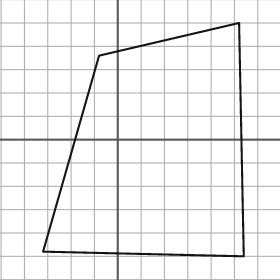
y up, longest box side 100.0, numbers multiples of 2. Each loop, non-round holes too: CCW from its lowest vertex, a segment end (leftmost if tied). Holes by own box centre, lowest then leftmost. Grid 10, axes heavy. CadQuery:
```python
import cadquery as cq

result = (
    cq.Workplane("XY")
    .moveTo(54.0, -50.0)
    .lineTo(52.0, 50.0)
    .lineTo(-8.0, 36.0)
    .lineTo(-32.0, -48.0)
    .close()
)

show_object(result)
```